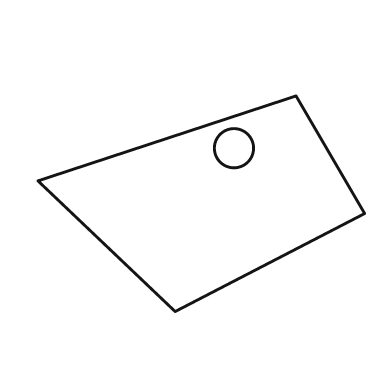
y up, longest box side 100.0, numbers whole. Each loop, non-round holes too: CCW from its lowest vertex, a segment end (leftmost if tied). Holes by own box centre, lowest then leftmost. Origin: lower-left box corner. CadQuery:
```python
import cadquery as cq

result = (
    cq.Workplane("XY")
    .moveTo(42.0, 0.0)
    .lineTo(100.0, 30.0)
    .lineTo(79.0, 66.0)
    .lineTo(0.0, 40.0)
    .close()
    .moveTo(60.0, 50.0)
    .circle(6.0)
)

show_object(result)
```